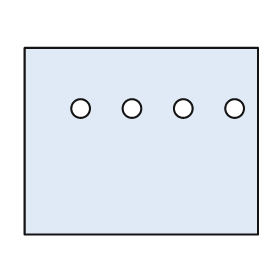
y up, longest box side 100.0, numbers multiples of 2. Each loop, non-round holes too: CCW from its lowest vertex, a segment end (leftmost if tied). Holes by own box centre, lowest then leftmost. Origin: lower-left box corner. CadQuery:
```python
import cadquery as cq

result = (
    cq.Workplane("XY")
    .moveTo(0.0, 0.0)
    .lineTo(100.0, 0.0)
    .lineTo(100.0, 80.0)
    .lineTo(0.0, 80.0)
    .close()
    .moveTo(24.0, 54.0)
    .circle(4.0)
    .moveTo(46.0, 54.0)
    .circle(4.0)
    .moveTo(68.0, 54.0)
    .circle(4.0)
    .moveTo(90.0, 54.0)
    .circle(4.0)
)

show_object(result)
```